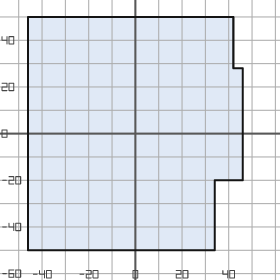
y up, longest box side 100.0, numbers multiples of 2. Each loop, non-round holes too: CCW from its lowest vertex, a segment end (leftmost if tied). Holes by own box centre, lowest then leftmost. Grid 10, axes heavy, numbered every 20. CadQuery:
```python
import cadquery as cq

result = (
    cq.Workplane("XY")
    .moveTo(-46.0, -50.0)
    .lineTo(34.0, -50.0)
    .lineTo(34.0, -20.0)
    .lineTo(46.0, -20.0)
    .lineTo(46.0, 28.0)
    .lineTo(42.0, 28.0)
    .lineTo(42.0, 50.0)
    .lineTo(-46.0, 50.0)
    .close()
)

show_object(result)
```